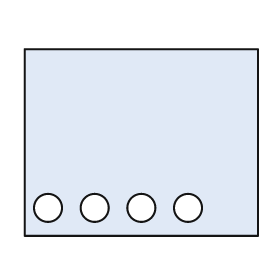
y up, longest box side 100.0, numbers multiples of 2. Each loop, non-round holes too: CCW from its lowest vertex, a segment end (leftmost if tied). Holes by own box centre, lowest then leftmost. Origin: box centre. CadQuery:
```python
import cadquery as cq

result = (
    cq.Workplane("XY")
    .moveTo(-50.0, -40.0)
    .lineTo(50.0, -40.0)
    .lineTo(50.0, 40.0)
    .lineTo(-50.0, 40.0)
    .close()
    .moveTo(-40.0, -28.0)
    .circle(6.0)
    .moveTo(-20.0, -28.0)
    .circle(6.0)
    .moveTo(0.0, -28.0)
    .circle(6.0)
    .moveTo(20.0, -28.0)
    .circle(6.0)
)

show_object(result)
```